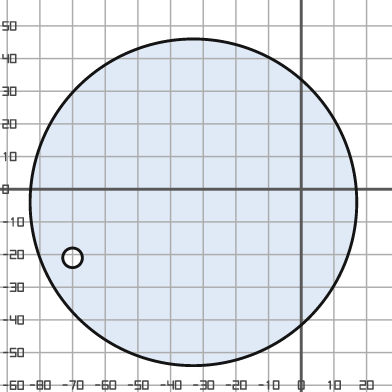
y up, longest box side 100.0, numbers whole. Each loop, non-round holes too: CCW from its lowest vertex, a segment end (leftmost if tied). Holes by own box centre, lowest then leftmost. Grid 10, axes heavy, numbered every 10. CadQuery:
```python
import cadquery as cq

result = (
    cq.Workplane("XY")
    .moveTo(-33.0, -4.0)
    .circle(50.0)
    .moveTo(-70.0, -21.0)
    .circle(3.0)
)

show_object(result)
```